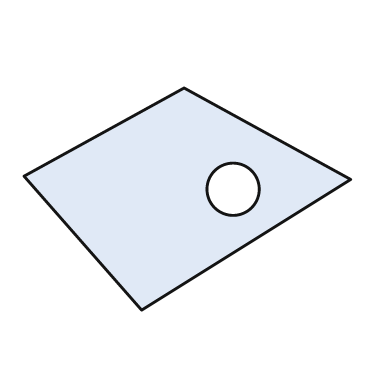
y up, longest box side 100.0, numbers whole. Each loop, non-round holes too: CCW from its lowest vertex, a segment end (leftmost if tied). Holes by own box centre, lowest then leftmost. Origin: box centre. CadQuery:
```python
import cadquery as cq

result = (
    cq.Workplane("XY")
    .moveTo(-14.0, -34.0)
    .lineTo(50.0, 6.0)
    .lineTo(-1.0, 34.0)
    .lineTo(-50.0, 7.0)
    .close()
    .moveTo(14.0, 3.0)
    .circle(8.0)
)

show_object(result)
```